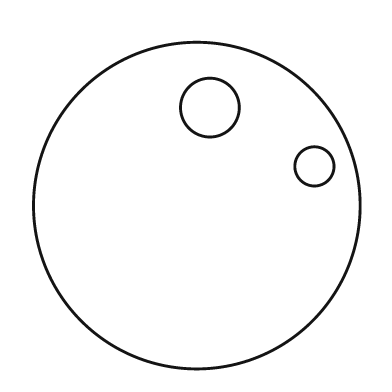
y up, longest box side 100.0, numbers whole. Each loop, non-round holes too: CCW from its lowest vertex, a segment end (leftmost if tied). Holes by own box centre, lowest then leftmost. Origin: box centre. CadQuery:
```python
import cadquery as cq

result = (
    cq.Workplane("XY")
    .moveTo(0.0, 0.0)
    .circle(50.0)
    .moveTo(36.0, 12.0)
    .circle(6.0)
    .moveTo(4.0, 30.0)
    .circle(9.0)
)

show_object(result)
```